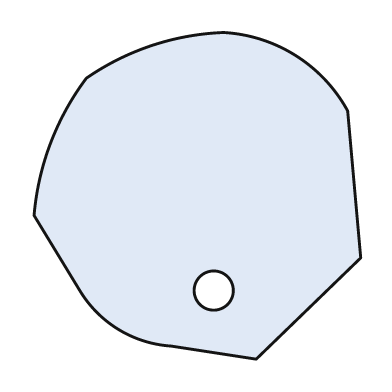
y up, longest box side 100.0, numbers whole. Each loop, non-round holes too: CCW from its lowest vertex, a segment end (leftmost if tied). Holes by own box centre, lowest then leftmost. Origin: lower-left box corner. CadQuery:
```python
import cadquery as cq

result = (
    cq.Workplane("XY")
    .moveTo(68.0, 0.0)
    .lineTo(100.0, 31.0)
    .lineTo(96.0, 76.0)
    .threePointArc((80.0, 93.0), (58.0, 100.0))
    .threePointArc((36.0, 96.0), (16.0, 86.0))
    .threePointArc((5.0, 66.0), (0.0, 44.0))
    .lineTo(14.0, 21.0)
    .threePointArc((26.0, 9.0), (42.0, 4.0))
    .close()
    .moveTo(55.0, 21.0)
    .circle(6.0)
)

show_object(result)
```